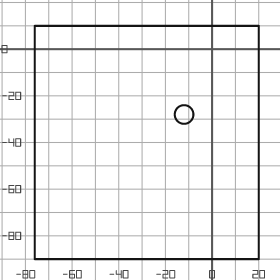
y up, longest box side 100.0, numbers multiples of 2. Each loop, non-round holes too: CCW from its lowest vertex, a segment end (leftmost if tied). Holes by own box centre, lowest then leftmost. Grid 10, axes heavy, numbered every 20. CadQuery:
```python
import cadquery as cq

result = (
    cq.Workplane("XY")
    .moveTo(-76.0, -90.0)
    .lineTo(20.0, -90.0)
    .lineTo(20.0, 10.0)
    .lineTo(-76.0, 10.0)
    .close()
    .moveTo(-12.0, -28.0)
    .circle(4.0)
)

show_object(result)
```